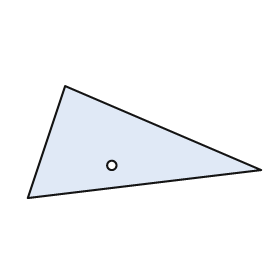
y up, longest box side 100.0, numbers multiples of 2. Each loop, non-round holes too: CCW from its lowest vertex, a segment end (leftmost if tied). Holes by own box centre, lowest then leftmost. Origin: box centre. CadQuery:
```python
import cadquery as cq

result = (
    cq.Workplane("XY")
    .moveTo(-50.0, -24.0)
    .lineTo(50.0, -12.0)
    .lineTo(-34.0, 24.0)
    .close()
    .moveTo(-14.0, -10.0)
    .circle(2.0)
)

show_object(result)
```